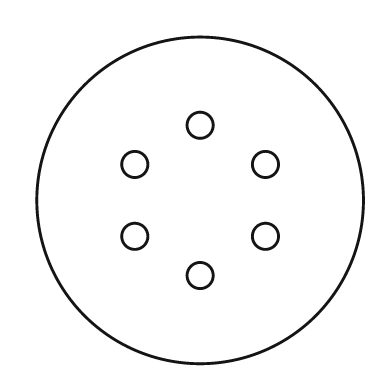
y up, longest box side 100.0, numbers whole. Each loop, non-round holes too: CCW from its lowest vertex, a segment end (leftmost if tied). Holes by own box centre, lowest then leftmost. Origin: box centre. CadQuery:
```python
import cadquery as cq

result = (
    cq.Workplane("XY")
    .moveTo(0.0, 0.0)
    .circle(50.0)
    .moveTo(0.0, -23.0)
    .circle(4.0)
    .moveTo(-20.0, -11.0)
    .circle(4.0)
    .moveTo(20.0, -11.0)
    .circle(4.0)
    .moveTo(-20.0, 11.0)
    .circle(4.0)
    .moveTo(20.0, 11.0)
    .circle(4.0)
    .moveTo(0.0, 23.0)
    .circle(4.0)
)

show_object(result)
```